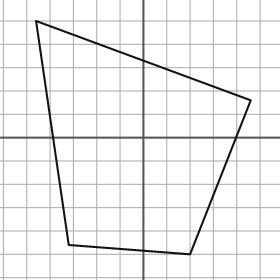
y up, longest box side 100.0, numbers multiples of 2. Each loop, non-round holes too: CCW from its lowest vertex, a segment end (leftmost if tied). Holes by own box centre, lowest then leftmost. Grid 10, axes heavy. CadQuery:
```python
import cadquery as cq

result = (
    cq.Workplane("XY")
    .moveTo(20.0, -50.0)
    .lineTo(46.0, 16.0)
    .lineTo(-46.0, 50.0)
    .lineTo(-32.0, -46.0)
    .close()
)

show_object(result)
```